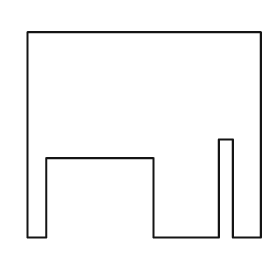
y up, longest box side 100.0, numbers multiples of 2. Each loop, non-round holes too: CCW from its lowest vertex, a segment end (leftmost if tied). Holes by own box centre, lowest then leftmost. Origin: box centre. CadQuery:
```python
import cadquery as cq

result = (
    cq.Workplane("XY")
    .moveTo(-50.0, -44.0)
    .lineTo(-42.0, -44.0)
    .lineTo(-42.0, -10.0)
    .lineTo(4.0, -10.0)
    .lineTo(4.0, -44.0)
    .lineTo(32.0, -44.0)
    .lineTo(32.0, -2.0)
    .lineTo(38.0, -2.0)
    .lineTo(38.0, -44.0)
    .lineTo(50.0, -44.0)
    .lineTo(50.0, 44.0)
    .lineTo(-50.0, 44.0)
    .close()
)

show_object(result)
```